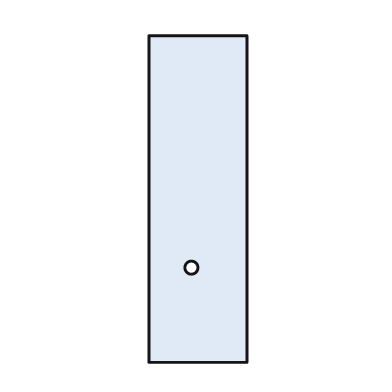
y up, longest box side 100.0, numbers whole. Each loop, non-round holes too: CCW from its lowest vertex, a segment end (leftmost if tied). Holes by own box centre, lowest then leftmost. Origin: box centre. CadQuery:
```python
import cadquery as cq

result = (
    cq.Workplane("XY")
    .moveTo(-15.0, -50.0)
    .lineTo(15.0, -50.0)
    .lineTo(15.0, 50.0)
    .lineTo(-15.0, 50.0)
    .close()
    .moveTo(-2.0, -21.0)
    .circle(2.0)
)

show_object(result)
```